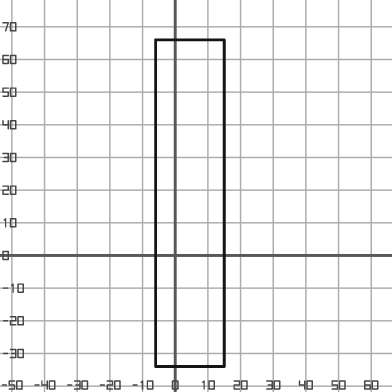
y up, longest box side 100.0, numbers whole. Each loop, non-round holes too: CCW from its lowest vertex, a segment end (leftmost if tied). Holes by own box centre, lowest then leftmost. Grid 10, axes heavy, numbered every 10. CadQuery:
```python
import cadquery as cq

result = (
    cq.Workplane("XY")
    .moveTo(-6.0, -34.0)
    .lineTo(15.0, -34.0)
    .lineTo(15.0, 66.0)
    .lineTo(-6.0, 66.0)
    .close()
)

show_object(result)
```